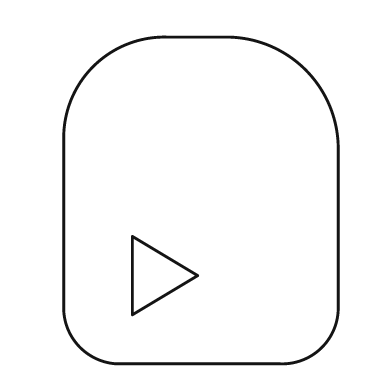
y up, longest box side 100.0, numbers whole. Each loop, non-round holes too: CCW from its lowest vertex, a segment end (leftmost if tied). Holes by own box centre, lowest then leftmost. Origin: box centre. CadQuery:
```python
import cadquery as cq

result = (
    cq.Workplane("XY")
    .moveTo(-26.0, -50.0)
    .lineTo(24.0, -50.0)
    .threePointArc((37.0, -45.0), (42.0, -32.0))
    .lineTo(42.0, 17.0)
    .threePointArc((32.0, 40.0), (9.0, 50.0))
    .lineTo(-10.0, 50.0)
    .threePointArc((-33.0, 41.0), (-42.0, 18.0))
    .lineTo(-42.0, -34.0)
    .threePointArc((-37.0, -45.0), (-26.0, -50.0))
    .close()
    .moveTo(-21.0, -35.0)
    .lineTo(-1.0, -23.0)
    .lineTo(-21.0, -11.0)
    .close()
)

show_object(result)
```